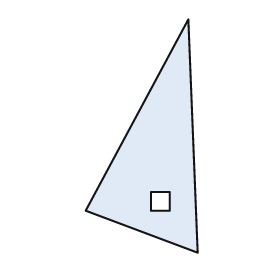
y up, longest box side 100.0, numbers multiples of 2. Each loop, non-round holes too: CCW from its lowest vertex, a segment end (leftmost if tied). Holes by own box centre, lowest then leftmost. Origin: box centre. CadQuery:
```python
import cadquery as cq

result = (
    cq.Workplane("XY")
    .moveTo(24.0, -50.0)
    .lineTo(20.0, 50.0)
    .lineTo(-24.0, -32.0)
    .close()
    .moveTo(4.0, -32.0)
    .lineTo(12.0, -32.0)
    .lineTo(12.0, -24.0)
    .lineTo(4.0, -24.0)
    .close()
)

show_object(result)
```